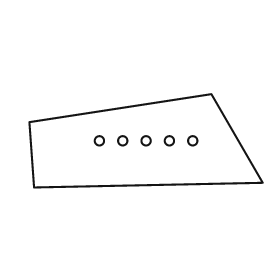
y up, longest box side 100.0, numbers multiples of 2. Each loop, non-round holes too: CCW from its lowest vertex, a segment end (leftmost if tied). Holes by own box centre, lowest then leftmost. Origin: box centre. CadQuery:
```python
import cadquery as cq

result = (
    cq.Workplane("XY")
    .moveTo(-48.0, -20.0)
    .lineTo(50.0, -18.0)
    .lineTo(28.0, 20.0)
    .lineTo(-50.0, 8.0)
    .close()
    .moveTo(-20.0, 0.0)
    .circle(2.0)
    .moveTo(-10.0, 0.0)
    .circle(2.0)
    .moveTo(0.0, 0.0)
    .circle(2.0)
    .moveTo(10.0, 0.0)
    .circle(2.0)
    .moveTo(20.0, 0.0)
    .circle(2.0)
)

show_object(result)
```